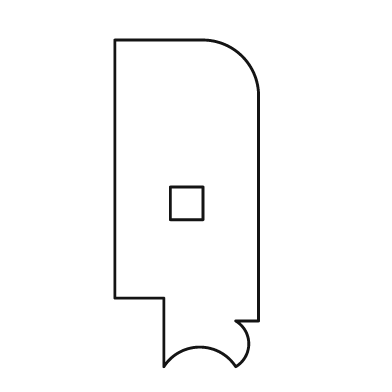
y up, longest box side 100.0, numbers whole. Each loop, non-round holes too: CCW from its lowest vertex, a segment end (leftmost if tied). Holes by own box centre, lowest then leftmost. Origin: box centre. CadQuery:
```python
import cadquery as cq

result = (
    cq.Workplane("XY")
    .moveTo(-7.0, -50.0)
    .threePointArc((4.0, -44.0), (15.0, -50.0))
    .threePointArc((19.0, -43.0), (15.0, -36.0))
    .lineTo(22.0, -36.0)
    .lineTo(22.0, 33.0)
    .threePointArc((17.0, 45.0), (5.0, 50.0))
    .lineTo(-22.0, 50.0)
    .lineTo(-22.0, -29.0)
    .lineTo(-7.0, -29.0)
    .close()
    .moveTo(-5.0, -5.0)
    .lineTo(5.0, -5.0)
    .lineTo(5.0, 5.0)
    .lineTo(-5.0, 5.0)
    .close()
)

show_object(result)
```